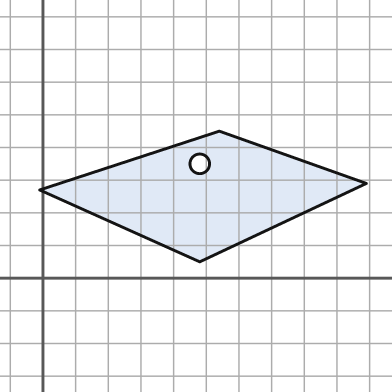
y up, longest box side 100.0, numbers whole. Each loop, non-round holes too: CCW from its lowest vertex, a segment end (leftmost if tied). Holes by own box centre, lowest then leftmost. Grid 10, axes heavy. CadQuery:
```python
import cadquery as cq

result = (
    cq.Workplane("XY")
    .moveTo(48.0, 5.0)
    .lineTo(99.0, 29.0)
    .lineTo(54.0, 45.0)
    .lineTo(-1.0, 27.0)
    .close()
    .moveTo(48.0, 35.0)
    .circle(3.0)
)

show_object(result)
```